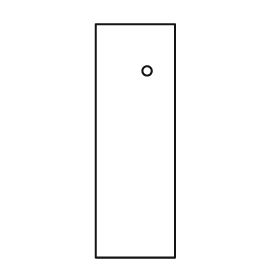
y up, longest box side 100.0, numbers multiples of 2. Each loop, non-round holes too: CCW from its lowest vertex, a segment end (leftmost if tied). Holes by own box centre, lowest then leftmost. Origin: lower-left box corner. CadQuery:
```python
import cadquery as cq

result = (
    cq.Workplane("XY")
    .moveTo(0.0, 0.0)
    .lineTo(34.0, 0.0)
    .lineTo(34.0, 100.0)
    .lineTo(0.0, 100.0)
    .close()
    .moveTo(22.0, 80.0)
    .circle(2.0)
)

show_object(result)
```